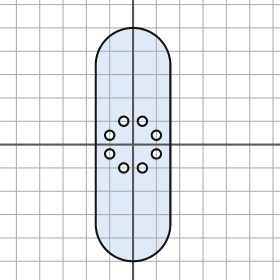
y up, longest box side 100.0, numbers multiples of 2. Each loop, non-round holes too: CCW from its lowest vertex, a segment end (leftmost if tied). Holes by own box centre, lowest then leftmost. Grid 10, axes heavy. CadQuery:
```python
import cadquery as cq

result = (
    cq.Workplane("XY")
    .moveTo(-16.0, -34.0)
    .threePointArc((0.0, -50.0), (16.0, -34.0))
    .lineTo(16.0, 34.0)
    .threePointArc((0.0, 50.0), (-16.0, 34.0))
    .close()
    .moveTo(-4.0, -10.0)
    .circle(2.0)
    .moveTo(4.0, -10.0)
    .circle(2.0)
    .moveTo(-10.0, -4.0)
    .circle(2.0)
    .moveTo(10.0, -4.0)
    .circle(2.0)
    .moveTo(-10.0, 4.0)
    .circle(2.0)
    .moveTo(10.0, 4.0)
    .circle(2.0)
    .moveTo(-4.0, 10.0)
    .circle(2.0)
    .moveTo(4.0, 10.0)
    .circle(2.0)
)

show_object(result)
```